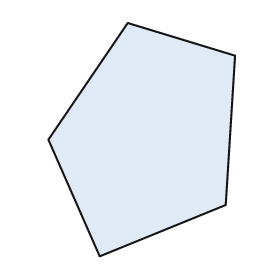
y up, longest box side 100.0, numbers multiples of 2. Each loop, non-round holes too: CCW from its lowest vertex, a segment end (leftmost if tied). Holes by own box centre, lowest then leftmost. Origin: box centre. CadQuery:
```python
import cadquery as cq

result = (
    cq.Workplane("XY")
    .moveTo(-18.0, -50.0)
    .lineTo(36.0, -28.0)
    .lineTo(40.0, 36.0)
    .lineTo(-6.0, 50.0)
    .lineTo(-40.0, 0.0)
    .close()
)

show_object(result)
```